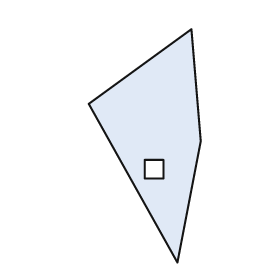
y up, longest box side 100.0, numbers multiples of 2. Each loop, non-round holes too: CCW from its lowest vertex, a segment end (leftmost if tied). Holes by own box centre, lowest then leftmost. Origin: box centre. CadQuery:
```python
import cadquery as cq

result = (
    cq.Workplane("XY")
    .moveTo(14.0, -50.0)
    .lineTo(24.0, 2.0)
    .lineTo(20.0, 50.0)
    .lineTo(-24.0, 18.0)
    .close()
    .moveTo(0.0, -14.0)
    .lineTo(8.0, -14.0)
    .lineTo(8.0, -6.0)
    .lineTo(0.0, -6.0)
    .close()
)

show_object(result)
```